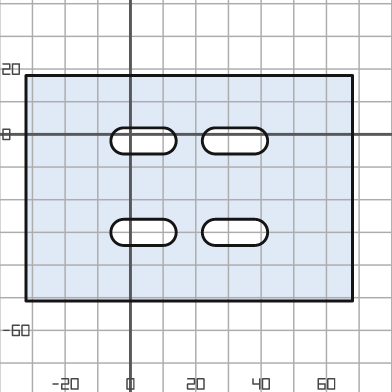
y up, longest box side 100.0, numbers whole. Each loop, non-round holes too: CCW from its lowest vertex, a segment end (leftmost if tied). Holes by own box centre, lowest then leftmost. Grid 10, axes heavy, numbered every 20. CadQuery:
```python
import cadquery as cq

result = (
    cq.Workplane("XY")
    .moveTo(-32.0, -51.0)
    .lineTo(68.0, -51.0)
    .lineTo(68.0, 18.0)
    .lineTo(-32.0, 18.0)
    .close()
    .moveTo(-2.0, -34.0)
    .lineTo(10.0, -34.0)
    .threePointArc((14.0, -30.0), (10.0, -26.0))
    .lineTo(-2.0, -26.0)
    .threePointArc((-6.0, -30.0), (-2.0, -34.0))
    .close()
    .moveTo(26.0, -34.0)
    .lineTo(38.0, -34.0)
    .threePointArc((42.0, -30.0), (38.0, -26.0))
    .lineTo(26.0, -26.0)
    .threePointArc((22.0, -30.0), (26.0, -34.0))
    .close()
    .moveTo(-2.0, -6.0)
    .lineTo(10.0, -6.0)
    .threePointArc((14.0, -2.0), (10.0, 2.0))
    .lineTo(-2.0, 2.0)
    .threePointArc((-6.0, -2.0), (-2.0, -6.0))
    .close()
    .moveTo(26.0, -6.0)
    .lineTo(38.0, -6.0)
    .threePointArc((42.0, -2.0), (38.0, 2.0))
    .lineTo(26.0, 2.0)
    .threePointArc((22.0, -2.0), (26.0, -6.0))
    .close()
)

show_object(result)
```